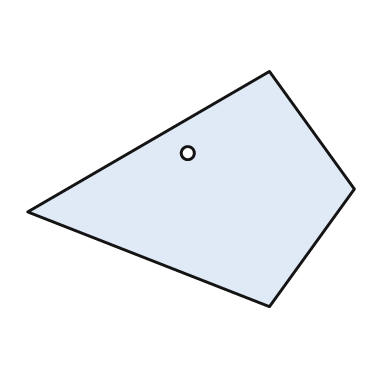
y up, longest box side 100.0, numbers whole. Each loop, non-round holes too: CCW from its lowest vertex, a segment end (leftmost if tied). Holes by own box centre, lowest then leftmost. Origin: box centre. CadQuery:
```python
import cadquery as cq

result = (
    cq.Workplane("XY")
    .moveTo(24.0, -36.0)
    .lineTo(50.0, 0.0)
    .lineTo(24.0, 36.0)
    .lineTo(-50.0, -7.0)
    .close()
    .moveTo(-1.0, 11.0)
    .circle(2.0)
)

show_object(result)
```